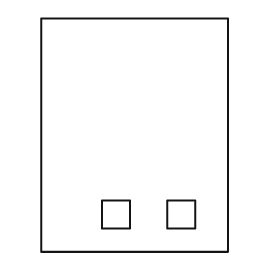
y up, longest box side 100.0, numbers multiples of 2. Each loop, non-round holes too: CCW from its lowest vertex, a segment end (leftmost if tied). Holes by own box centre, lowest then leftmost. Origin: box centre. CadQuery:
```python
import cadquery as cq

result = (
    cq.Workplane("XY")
    .moveTo(-40.0, -50.0)
    .lineTo(40.0, -50.0)
    .lineTo(40.0, 50.0)
    .lineTo(-40.0, 50.0)
    .close()
    .moveTo(-14.0, -40.0)
    .lineTo(-2.0, -40.0)
    .lineTo(-2.0, -28.0)
    .lineTo(-14.0, -28.0)
    .close()
    .moveTo(14.0, -40.0)
    .lineTo(26.0, -40.0)
    .lineTo(26.0, -28.0)
    .lineTo(14.0, -28.0)
    .close()
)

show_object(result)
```